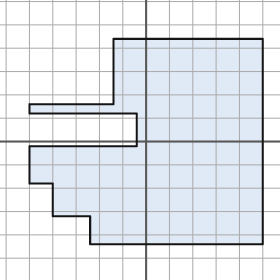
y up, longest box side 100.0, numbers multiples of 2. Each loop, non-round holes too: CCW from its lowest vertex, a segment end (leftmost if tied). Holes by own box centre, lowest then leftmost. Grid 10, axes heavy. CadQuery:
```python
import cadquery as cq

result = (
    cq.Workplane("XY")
    .moveTo(-24.0, -44.0)
    .lineTo(50.0, -44.0)
    .lineTo(50.0, 44.0)
    .lineTo(-14.0, 44.0)
    .lineTo(-14.0, 16.0)
    .lineTo(-50.0, 16.0)
    .lineTo(-50.0, 12.0)
    .lineTo(-4.0, 12.0)
    .lineTo(-4.0, -2.0)
    .lineTo(-50.0, -2.0)
    .lineTo(-50.0, -18.0)
    .lineTo(-40.0, -18.0)
    .lineTo(-40.0, -32.0)
    .lineTo(-24.0, -32.0)
    .close()
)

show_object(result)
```